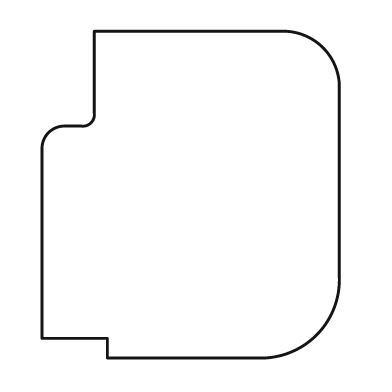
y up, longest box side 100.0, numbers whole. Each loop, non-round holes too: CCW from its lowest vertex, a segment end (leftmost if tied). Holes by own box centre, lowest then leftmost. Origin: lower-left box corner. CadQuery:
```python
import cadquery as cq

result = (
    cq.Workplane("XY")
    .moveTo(20.0, 0.0)
    .lineTo(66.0, 0.0)
    .threePointArc((84.0, 7.0), (91.0, 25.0))
    .lineTo(91.0, 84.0)
    .threePointArc((86.0, 95.0), (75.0, 100.0))
    .lineTo(16.0, 100.0)
    .lineTo(16.0, 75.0)
    .threePointArc((15.0, 72.0), (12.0, 71.0))
    .lineTo(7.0, 71.0)
    .threePointArc((2.0, 69.0), (0.0, 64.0))
    .lineTo(0.0, 6.0)
    .lineTo(20.0, 6.0)
    .close()
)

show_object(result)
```